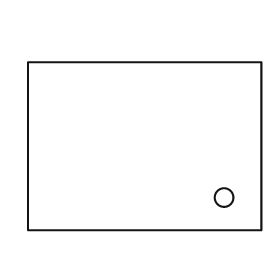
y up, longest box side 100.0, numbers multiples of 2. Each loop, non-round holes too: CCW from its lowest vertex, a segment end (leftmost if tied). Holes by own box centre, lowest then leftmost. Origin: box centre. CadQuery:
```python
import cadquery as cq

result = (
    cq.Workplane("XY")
    .moveTo(-50.0, -36.0)
    .lineTo(50.0, -36.0)
    .lineTo(50.0, 36.0)
    .lineTo(-50.0, 36.0)
    .close()
    .moveTo(34.0, -22.0)
    .circle(4.0)
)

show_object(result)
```